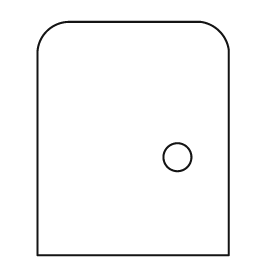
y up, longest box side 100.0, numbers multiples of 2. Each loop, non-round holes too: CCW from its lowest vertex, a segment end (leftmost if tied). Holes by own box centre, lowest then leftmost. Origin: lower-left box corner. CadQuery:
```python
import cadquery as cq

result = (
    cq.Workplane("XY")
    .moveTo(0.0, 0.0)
    .lineTo(82.0, 0.0)
    .lineTo(82.0, 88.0)
    .threePointArc((78.0, 96.0), (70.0, 100.0))
    .lineTo(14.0, 100.0)
    .threePointArc((4.0, 96.0), (0.0, 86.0))
    .close()
    .moveTo(60.0, 42.0)
    .circle(6.0)
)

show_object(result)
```